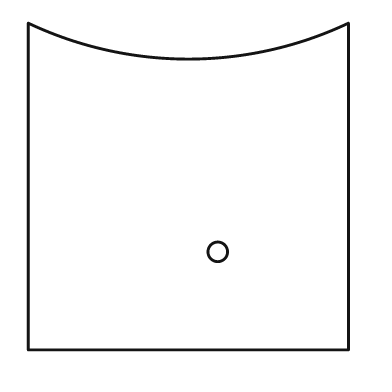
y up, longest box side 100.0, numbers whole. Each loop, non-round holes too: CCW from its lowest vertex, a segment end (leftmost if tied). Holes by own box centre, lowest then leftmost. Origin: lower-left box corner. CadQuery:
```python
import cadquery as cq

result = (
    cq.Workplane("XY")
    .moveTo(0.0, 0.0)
    .lineTo(98.0, 0.0)
    .lineTo(98.0, 100.0)
    .threePointArc((49.0, 89.0), (0.0, 100.0))
    .close()
    .moveTo(58.0, 30.0)
    .circle(3.0)
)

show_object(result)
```